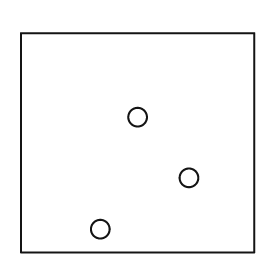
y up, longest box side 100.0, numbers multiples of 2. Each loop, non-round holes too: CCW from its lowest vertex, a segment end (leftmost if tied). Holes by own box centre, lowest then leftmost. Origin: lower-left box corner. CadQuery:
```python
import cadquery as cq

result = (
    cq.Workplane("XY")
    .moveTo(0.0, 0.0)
    .lineTo(100.0, 0.0)
    .lineTo(100.0, 94.0)
    .lineTo(0.0, 94.0)
    .close()
    .moveTo(34.0, 10.0)
    .circle(4.0)
    .moveTo(72.0, 32.0)
    .circle(4.0)
    .moveTo(50.0, 58.0)
    .circle(4.0)
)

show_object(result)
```